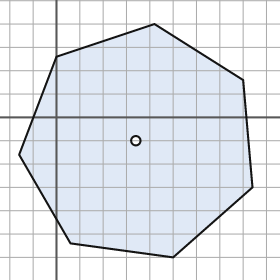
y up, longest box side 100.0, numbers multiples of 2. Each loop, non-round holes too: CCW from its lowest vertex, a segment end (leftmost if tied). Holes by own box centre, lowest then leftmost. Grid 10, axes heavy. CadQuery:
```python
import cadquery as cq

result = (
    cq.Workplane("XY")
    .moveTo(50.0, -60.0)
    .lineTo(84.0, -30.0)
    .lineTo(80.0, 16.0)
    .lineTo(42.0, 40.0)
    .lineTo(0.0, 26.0)
    .lineTo(-16.0, -16.0)
    .lineTo(6.0, -54.0)
    .close()
    .moveTo(34.0, -10.0)
    .circle(2.0)
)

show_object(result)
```